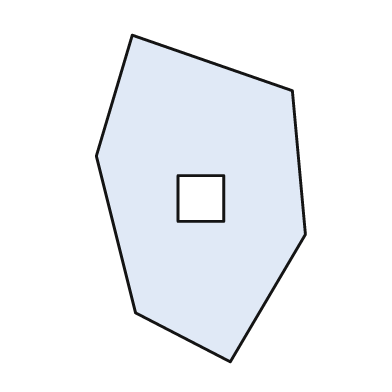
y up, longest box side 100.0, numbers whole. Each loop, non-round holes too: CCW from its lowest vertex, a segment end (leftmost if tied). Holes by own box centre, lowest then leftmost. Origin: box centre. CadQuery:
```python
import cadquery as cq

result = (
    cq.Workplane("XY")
    .moveTo(9.0, -50.0)
    .lineTo(32.0, -11.0)
    .lineTo(28.0, 33.0)
    .lineTo(-21.0, 50.0)
    .lineTo(-32.0, 13.0)
    .lineTo(-20.0, -35.0)
    .close()
    .moveTo(-7.0, -7.0)
    .lineTo(7.0, -7.0)
    .lineTo(7.0, 7.0)
    .lineTo(-7.0, 7.0)
    .close()
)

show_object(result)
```